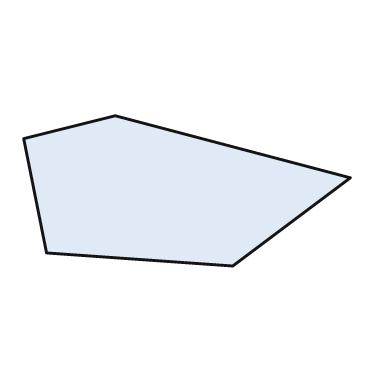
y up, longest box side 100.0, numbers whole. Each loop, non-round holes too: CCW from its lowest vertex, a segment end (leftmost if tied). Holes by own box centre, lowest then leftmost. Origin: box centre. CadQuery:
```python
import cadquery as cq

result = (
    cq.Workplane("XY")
    .moveTo(14.0, -23.0)
    .lineTo(50.0, 4.0)
    .lineTo(-22.0, 23.0)
    .lineTo(-50.0, 16.0)
    .lineTo(-43.0, -19.0)
    .close()
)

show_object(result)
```